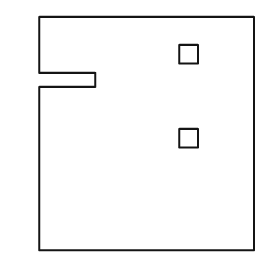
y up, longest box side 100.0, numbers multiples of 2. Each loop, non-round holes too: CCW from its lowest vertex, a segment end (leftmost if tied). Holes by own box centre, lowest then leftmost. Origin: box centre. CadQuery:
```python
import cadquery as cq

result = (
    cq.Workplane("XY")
    .moveTo(-46.0, -50.0)
    .lineTo(46.0, -50.0)
    .lineTo(46.0, 50.0)
    .lineTo(-46.0, 50.0)
    .lineTo(-46.0, 26.0)
    .lineTo(-22.0, 26.0)
    .lineTo(-22.0, 20.0)
    .lineTo(-46.0, 20.0)
    .close()
    .moveTo(14.0, -6.0)
    .lineTo(22.0, -6.0)
    .lineTo(22.0, 2.0)
    .lineTo(14.0, 2.0)
    .close()
    .moveTo(14.0, 30.0)
    .lineTo(22.0, 30.0)
    .lineTo(22.0, 38.0)
    .lineTo(14.0, 38.0)
    .close()
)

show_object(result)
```